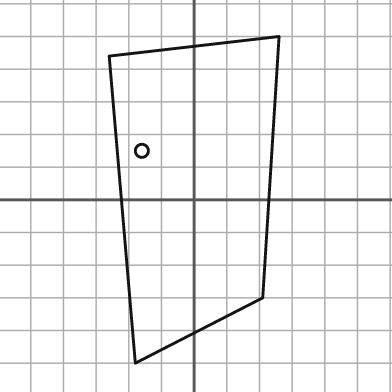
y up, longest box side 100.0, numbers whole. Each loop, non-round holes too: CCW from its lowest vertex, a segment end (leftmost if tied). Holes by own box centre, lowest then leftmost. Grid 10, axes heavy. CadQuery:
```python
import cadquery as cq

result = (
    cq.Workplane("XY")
    .moveTo(-18.0, -50.0)
    .lineTo(21.0, -30.0)
    .lineTo(26.0, 50.0)
    .lineTo(-26.0, 44.0)
    .close()
    .moveTo(-16.0, 15.0)
    .circle(2.0)
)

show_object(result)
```